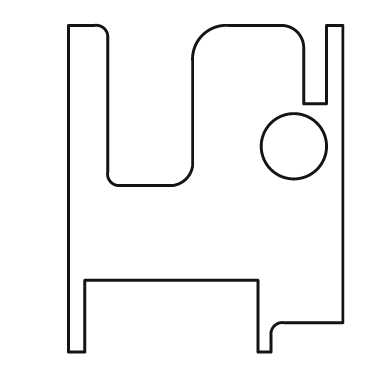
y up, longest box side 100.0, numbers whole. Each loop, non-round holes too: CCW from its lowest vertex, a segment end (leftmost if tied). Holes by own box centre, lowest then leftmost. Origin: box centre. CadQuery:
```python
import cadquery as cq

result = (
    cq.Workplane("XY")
    .moveTo(-42.0, -50.0)
    .lineTo(-37.0, -50.0)
    .lineTo(-37.0, -28.0)
    .lineTo(16.0, -28.0)
    .lineTo(16.0, -50.0)
    .lineTo(20.0, -50.0)
    .lineTo(20.0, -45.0)
    .threePointArc((21.0, -42.0), (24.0, -41.0))
    .lineTo(42.0, -41.0)
    .lineTo(42.0, 50.0)
    .lineTo(37.0, 50.0)
    .lineTo(37.0, 26.0)
    .lineTo(30.0, 26.0)
    .lineTo(30.0, 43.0)
    .threePointArc((28.0, 48.0), (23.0, 50.0))
    .lineTo(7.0, 50.0)
    .threePointArc((-1.0, 47.0), (-4.0, 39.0))
    .lineTo(-4.0, 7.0)
    .threePointArc((-6.0, 3.0), (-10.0, 1.0))
    .lineTo(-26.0, 1.0)
    .threePointArc((-29.0, 2.0), (-30.0, 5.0))
    .lineTo(-30.0, 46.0)
    .threePointArc((-31.0, 49.0), (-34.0, 50.0))
    .lineTo(-42.0, 50.0)
    .close()
    .moveTo(27.0, 13.0)
    .circle(10.0)
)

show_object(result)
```